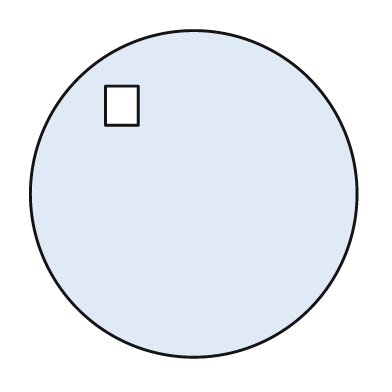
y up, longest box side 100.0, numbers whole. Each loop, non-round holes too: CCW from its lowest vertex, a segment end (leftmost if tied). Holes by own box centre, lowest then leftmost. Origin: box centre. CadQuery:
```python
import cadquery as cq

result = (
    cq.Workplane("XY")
    .moveTo(0.0, 0.0)
    .circle(50.0)
    .moveTo(-27.0, 21.0)
    .lineTo(-17.0, 21.0)
    .lineTo(-17.0, 33.0)
    .lineTo(-27.0, 33.0)
    .close()
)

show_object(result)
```